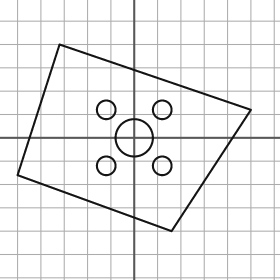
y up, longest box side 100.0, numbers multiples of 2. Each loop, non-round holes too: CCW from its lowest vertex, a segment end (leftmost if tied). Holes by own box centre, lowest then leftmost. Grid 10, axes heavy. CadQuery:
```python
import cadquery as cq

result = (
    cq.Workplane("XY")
    .moveTo(16.0, -40.0)
    .lineTo(50.0, 12.0)
    .lineTo(-32.0, 40.0)
    .lineTo(-50.0, -16.0)
    .close()
    .moveTo(-12.0, -12.0)
    .circle(4.0)
    .moveTo(12.0, -12.0)
    .circle(4.0)
    .moveTo(0.0, 0.0)
    .circle(8.0)
    .moveTo(-12.0, 12.0)
    .circle(4.0)
    .moveTo(12.0, 12.0)
    .circle(4.0)
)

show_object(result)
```